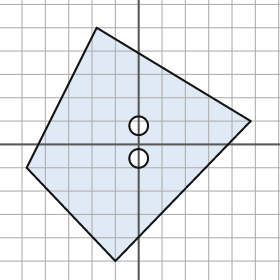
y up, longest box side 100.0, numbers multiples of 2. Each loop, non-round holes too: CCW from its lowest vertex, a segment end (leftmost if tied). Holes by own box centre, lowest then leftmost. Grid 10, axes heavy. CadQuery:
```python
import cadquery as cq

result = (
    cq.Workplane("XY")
    .moveTo(-10.0, -50.0)
    .lineTo(48.0, 10.0)
    .lineTo(-18.0, 50.0)
    .lineTo(-48.0, -10.0)
    .close()
    .moveTo(0.0, -6.0)
    .circle(4.0)
    .moveTo(0.0, 8.0)
    .circle(4.0)
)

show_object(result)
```